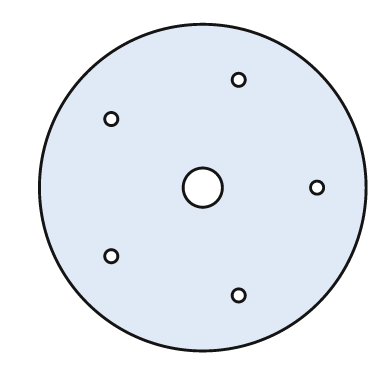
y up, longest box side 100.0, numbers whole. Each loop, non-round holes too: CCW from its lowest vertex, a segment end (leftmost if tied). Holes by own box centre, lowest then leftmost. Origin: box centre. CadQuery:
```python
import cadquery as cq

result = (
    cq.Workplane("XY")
    .moveTo(0.0, 0.0)
    .circle(50.0)
    .moveTo(11.0, -33.0)
    .circle(2.0)
    .moveTo(-28.0, -21.0)
    .circle(2.0)
    .moveTo(0.0, 0.0)
    .circle(6.0)
    .moveTo(35.0, 0.0)
    .circle(2.0)
    .moveTo(-28.0, 21.0)
    .circle(2.0)
    .moveTo(11.0, 33.0)
    .circle(2.0)
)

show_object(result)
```